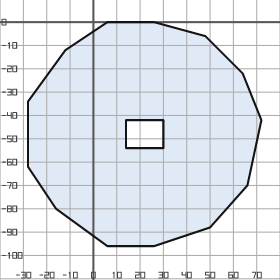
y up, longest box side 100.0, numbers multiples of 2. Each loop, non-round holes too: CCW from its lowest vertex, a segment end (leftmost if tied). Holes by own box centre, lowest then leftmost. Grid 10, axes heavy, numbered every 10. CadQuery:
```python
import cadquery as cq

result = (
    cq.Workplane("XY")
    .moveTo(6.0, -96.0)
    .lineTo(26.0, -96.0)
    .lineTo(50.0, -88.0)
    .lineTo(66.0, -70.0)
    .lineTo(72.0, -42.0)
    .lineTo(64.0, -22.0)
    .lineTo(48.0, -6.0)
    .lineTo(26.0, 0.0)
    .lineTo(6.0, 0.0)
    .lineTo(-12.0, -12.0)
    .lineTo(-28.0, -34.0)
    .lineTo(-28.0, -62.0)
    .lineTo(-16.0, -80.0)
    .close()
    .moveTo(14.0, -54.0)
    .lineTo(30.0, -54.0)
    .lineTo(30.0, -42.0)
    .lineTo(14.0, -42.0)
    .close()
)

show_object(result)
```